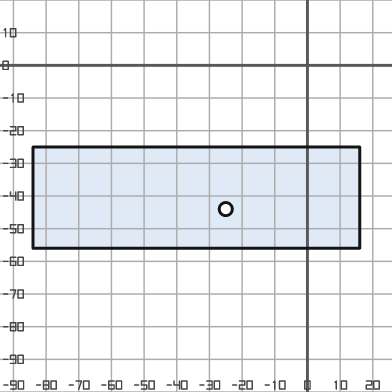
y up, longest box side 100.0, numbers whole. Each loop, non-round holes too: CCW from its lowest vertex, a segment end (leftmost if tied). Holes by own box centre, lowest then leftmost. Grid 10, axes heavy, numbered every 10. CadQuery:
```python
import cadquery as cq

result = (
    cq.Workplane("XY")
    .moveTo(-84.0, -56.0)
    .lineTo(16.0, -56.0)
    .lineTo(16.0, -25.0)
    .lineTo(-84.0, -25.0)
    .close()
    .moveTo(-25.0, -44.0)
    .circle(2.0)
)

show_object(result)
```